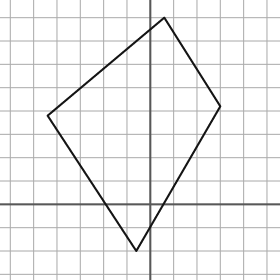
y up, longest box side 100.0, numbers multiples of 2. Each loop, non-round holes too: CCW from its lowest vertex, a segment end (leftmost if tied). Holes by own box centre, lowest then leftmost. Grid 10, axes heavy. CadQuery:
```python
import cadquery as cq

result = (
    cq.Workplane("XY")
    .moveTo(-6.0, -20.0)
    .lineTo(30.0, 42.0)
    .lineTo(6.0, 80.0)
    .lineTo(-44.0, 38.0)
    .close()
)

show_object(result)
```